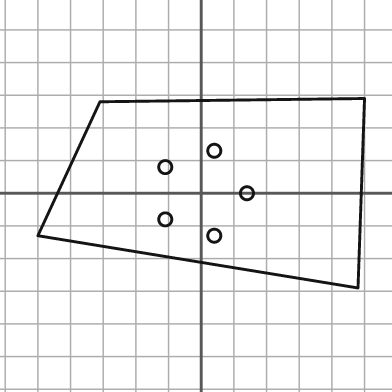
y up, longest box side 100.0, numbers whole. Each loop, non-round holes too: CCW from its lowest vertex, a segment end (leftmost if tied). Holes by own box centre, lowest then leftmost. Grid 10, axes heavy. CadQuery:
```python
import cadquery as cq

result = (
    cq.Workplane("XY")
    .moveTo(48.0, -29.0)
    .lineTo(50.0, 29.0)
    .lineTo(-31.0, 28.0)
    .lineTo(-50.0, -13.0)
    .close()
    .moveTo(4.0, -13.0)
    .circle(2.0)
    .moveTo(-11.0, -8.0)
    .circle(2.0)
    .moveTo(14.0, 0.0)
    .circle(2.0)
    .moveTo(-11.0, 8.0)
    .circle(2.0)
    .moveTo(4.0, 13.0)
    .circle(2.0)
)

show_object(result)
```